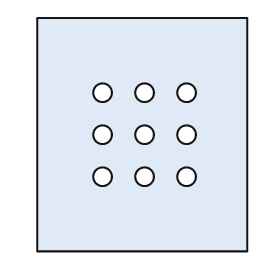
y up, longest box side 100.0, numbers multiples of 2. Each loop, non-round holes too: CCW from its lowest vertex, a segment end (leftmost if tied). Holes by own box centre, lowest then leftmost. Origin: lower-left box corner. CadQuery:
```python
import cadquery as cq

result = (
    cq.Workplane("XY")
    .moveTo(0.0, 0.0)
    .lineTo(90.0, 0.0)
    .lineTo(90.0, 100.0)
    .lineTo(0.0, 100.0)
    .close()
    .moveTo(28.0, 32.0)
    .circle(4.0)
    .moveTo(46.0, 32.0)
    .circle(4.0)
    .moveTo(64.0, 32.0)
    .circle(4.0)
    .moveTo(28.0, 50.0)
    .circle(4.0)
    .moveTo(46.0, 50.0)
    .circle(4.0)
    .moveTo(64.0, 50.0)
    .circle(4.0)
    .moveTo(28.0, 68.0)
    .circle(4.0)
    .moveTo(46.0, 68.0)
    .circle(4.0)
    .moveTo(64.0, 68.0)
    .circle(4.0)
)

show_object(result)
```